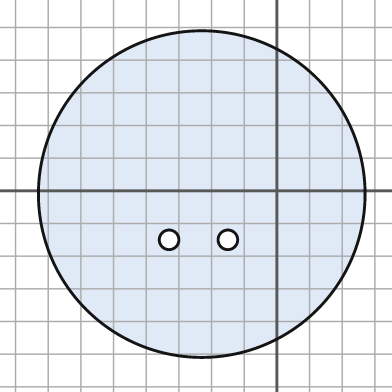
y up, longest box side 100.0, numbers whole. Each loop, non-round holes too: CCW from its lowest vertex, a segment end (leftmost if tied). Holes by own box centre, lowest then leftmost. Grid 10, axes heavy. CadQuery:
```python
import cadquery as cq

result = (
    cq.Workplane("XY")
    .moveTo(-23.0, -1.0)
    .circle(50.0)
    .moveTo(-33.0, -15.0)
    .circle(3.0)
    .moveTo(-15.0, -15.0)
    .circle(3.0)
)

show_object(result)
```